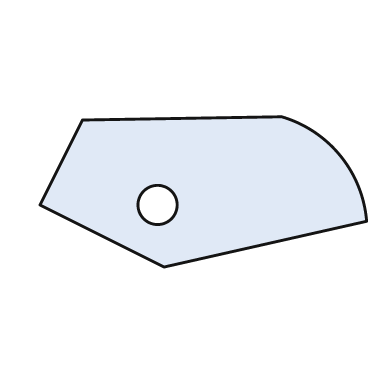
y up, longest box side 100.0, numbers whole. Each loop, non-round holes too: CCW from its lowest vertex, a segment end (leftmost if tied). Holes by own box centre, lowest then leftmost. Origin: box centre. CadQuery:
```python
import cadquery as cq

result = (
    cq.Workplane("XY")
    .moveTo(-12.0, -23.0)
    .lineTo(50.0, -9.0)
    .threePointArc((42.0, 11.0), (24.0, 23.0))
    .lineTo(-37.0, 22.0)
    .lineTo(-50.0, -4.0)
    .close()
    .moveTo(-14.0, -4.0)
    .circle(6.0)
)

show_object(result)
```